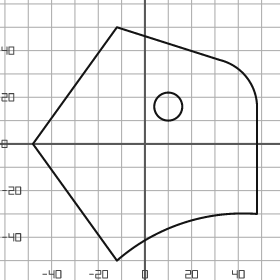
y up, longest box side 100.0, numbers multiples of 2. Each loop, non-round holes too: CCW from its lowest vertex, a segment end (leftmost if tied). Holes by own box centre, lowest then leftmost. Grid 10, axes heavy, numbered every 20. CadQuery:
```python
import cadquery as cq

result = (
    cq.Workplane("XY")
    .moveTo(-12.0, -50.0)
    .threePointArc((16.0, -34.0), (48.0, -30.0))
    .lineTo(48.0, 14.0)
    .threePointArc((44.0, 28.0), (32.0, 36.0))
    .lineTo(-12.0, 50.0)
    .lineTo(-48.0, 0.0)
    .close()
    .moveTo(10.0, 16.0)
    .circle(6.0)
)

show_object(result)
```